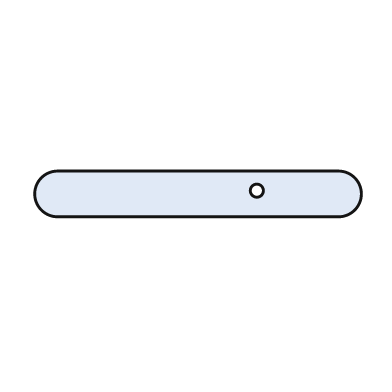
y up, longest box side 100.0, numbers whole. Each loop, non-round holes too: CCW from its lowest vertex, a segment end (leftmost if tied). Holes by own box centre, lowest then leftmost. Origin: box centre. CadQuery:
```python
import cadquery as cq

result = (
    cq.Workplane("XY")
    .moveTo(-43.0, -7.0)
    .lineTo(43.0, -7.0)
    .threePointArc((50.0, 0.0), (43.0, 7.0))
    .lineTo(-43.0, 7.0)
    .threePointArc((-50.0, 0.0), (-43.0, -7.0))
    .close()
    .moveTo(18.0, 1.0)
    .circle(2.0)
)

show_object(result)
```